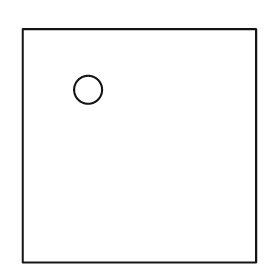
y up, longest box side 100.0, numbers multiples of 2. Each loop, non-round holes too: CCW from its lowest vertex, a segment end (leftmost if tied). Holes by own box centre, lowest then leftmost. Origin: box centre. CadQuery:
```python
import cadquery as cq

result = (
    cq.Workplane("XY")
    .moveTo(-50.0, -50.0)
    .lineTo(50.0, -50.0)
    .lineTo(50.0, 50.0)
    .lineTo(-50.0, 50.0)
    .close()
    .moveTo(-22.0, 24.0)
    .circle(6.0)
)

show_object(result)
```